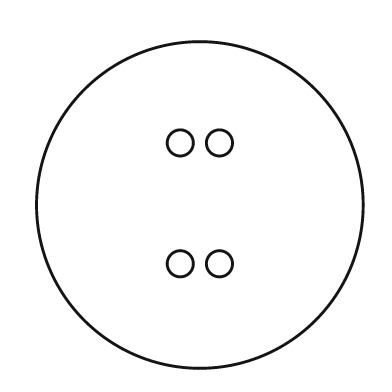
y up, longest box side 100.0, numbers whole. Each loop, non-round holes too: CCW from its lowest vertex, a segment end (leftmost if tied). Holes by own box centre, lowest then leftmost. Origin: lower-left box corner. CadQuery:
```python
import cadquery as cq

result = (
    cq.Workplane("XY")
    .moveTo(50.0, 50.0)
    .circle(50.0)
    .moveTo(44.0, 32.0)
    .circle(4.0)
    .moveTo(56.0, 32.0)
    .circle(4.0)
    .moveTo(44.0, 69.0)
    .circle(4.0)
    .moveTo(56.0, 69.0)
    .circle(4.0)
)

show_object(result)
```